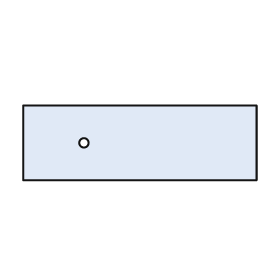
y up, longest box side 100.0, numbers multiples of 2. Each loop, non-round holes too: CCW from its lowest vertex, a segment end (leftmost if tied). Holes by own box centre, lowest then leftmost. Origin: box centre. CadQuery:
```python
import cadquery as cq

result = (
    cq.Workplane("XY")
    .moveTo(-50.0, -16.0)
    .lineTo(50.0, -16.0)
    .lineTo(50.0, 16.0)
    .lineTo(-50.0, 16.0)
    .close()
    .moveTo(-24.0, 0.0)
    .circle(2.0)
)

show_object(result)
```